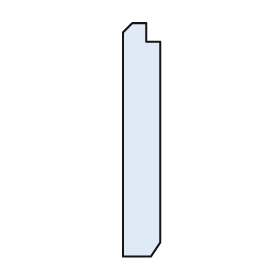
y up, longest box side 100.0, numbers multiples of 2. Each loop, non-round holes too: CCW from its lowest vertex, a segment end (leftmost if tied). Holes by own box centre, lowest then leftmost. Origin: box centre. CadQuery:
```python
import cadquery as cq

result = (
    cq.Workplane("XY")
    .moveTo(-8.0, -50.0)
    .lineTo(4.0, -50.0)
    .lineTo(8.0, -44.0)
    .lineTo(8.0, 42.0)
    .lineTo(2.0, 42.0)
    .lineTo(2.0, 50.0)
    .lineTo(-4.0, 50.0)
    .lineTo(-8.0, 46.0)
    .close()
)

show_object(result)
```